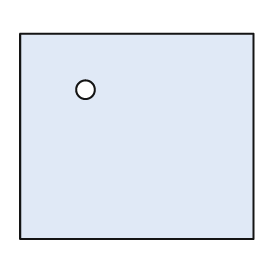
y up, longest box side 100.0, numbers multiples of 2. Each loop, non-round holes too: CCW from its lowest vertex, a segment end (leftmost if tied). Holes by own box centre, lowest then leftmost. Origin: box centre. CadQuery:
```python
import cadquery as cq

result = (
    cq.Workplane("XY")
    .moveTo(-50.0, -44.0)
    .lineTo(50.0, -44.0)
    .lineTo(50.0, 44.0)
    .lineTo(-50.0, 44.0)
    .close()
    .moveTo(-22.0, 20.0)
    .circle(4.0)
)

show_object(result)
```